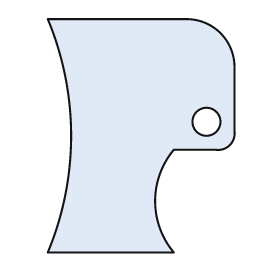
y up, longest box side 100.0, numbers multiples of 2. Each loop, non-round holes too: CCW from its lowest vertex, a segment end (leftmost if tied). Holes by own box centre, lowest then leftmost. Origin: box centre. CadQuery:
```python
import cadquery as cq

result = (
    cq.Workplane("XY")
    .moveTo(-40.0, -50.0)
    .lineTo(14.0, -50.0)
    .threePointArc((6.0, -28.0), (14.0, -6.0))
    .lineTo(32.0, -6.0)
    .threePointArc((38.0, -4.0), (40.0, 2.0))
    .lineTo(40.0, 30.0)
    .threePointArc((34.0, 44.0), (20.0, 50.0))
    .lineTo(-40.0, 50.0)
    .threePointArc((-30.0, 0.0), (-40.0, -50.0))
    .close()
    .moveTo(28.0, 6.0)
    .circle(6.0)
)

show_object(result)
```